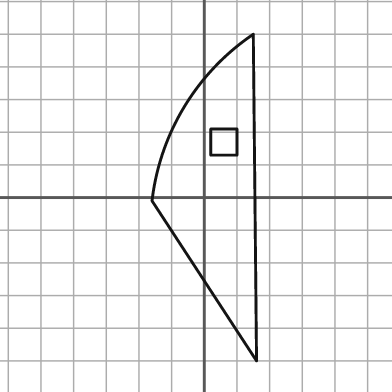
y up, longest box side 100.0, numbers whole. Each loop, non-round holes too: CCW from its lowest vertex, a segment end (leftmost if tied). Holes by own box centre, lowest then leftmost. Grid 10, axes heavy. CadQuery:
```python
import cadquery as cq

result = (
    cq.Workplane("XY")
    .moveTo(16.0, -50.0)
    .lineTo(15.0, 50.0)
    .threePointArc((-6.0, 28.0), (-16.0, -1.0))
    .close()
    .moveTo(2.0, 13.0)
    .lineTo(10.0, 13.0)
    .lineTo(10.0, 21.0)
    .lineTo(2.0, 21.0)
    .close()
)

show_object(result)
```